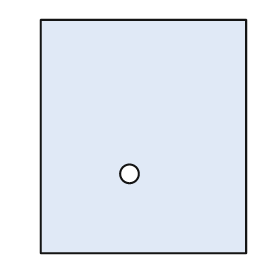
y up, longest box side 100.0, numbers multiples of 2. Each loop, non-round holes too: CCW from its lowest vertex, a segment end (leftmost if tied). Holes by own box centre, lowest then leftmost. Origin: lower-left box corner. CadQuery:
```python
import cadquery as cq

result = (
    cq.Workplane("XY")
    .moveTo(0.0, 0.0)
    .lineTo(88.0, 0.0)
    .lineTo(88.0, 100.0)
    .lineTo(0.0, 100.0)
    .close()
    .moveTo(38.0, 34.0)
    .circle(4.0)
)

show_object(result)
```